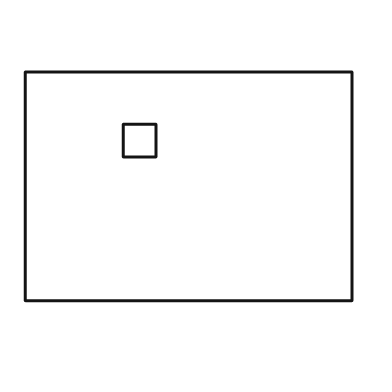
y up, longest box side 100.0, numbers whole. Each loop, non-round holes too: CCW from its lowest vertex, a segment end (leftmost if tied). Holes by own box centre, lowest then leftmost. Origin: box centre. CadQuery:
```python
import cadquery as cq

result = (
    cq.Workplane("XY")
    .moveTo(-50.0, -35.0)
    .lineTo(50.0, -35.0)
    .lineTo(50.0, 35.0)
    .lineTo(-50.0, 35.0)
    .close()
    .moveTo(-20.0, 9.0)
    .lineTo(-10.0, 9.0)
    .lineTo(-10.0, 19.0)
    .lineTo(-20.0, 19.0)
    .close()
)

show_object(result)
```